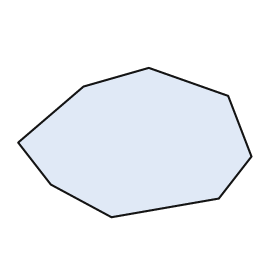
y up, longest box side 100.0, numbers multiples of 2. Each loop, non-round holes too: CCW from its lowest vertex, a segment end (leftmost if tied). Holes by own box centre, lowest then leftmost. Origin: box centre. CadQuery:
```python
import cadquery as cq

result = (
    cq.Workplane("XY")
    .moveTo(-10.0, -32.0)
    .lineTo(36.0, -24.0)
    .lineTo(50.0, -6.0)
    .lineTo(40.0, 20.0)
    .lineTo(6.0, 32.0)
    .lineTo(-22.0, 24.0)
    .lineTo(-50.0, 0.0)
    .lineTo(-36.0, -18.0)
    .close()
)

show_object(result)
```